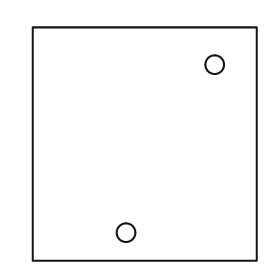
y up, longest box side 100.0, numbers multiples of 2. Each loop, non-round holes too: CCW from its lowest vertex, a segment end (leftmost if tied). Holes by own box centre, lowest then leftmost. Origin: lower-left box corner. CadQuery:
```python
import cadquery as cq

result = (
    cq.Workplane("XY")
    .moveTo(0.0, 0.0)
    .lineTo(96.0, 0.0)
    .lineTo(96.0, 100.0)
    .lineTo(0.0, 100.0)
    .close()
    .moveTo(40.0, 12.0)
    .circle(4.0)
    .moveTo(78.0, 84.0)
    .circle(4.0)
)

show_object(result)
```